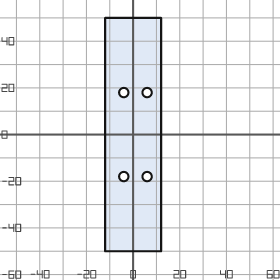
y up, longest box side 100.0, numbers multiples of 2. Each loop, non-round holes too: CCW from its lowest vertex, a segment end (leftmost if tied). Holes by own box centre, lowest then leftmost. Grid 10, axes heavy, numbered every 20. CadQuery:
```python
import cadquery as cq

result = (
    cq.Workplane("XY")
    .moveTo(-12.0, -50.0)
    .lineTo(12.0, -50.0)
    .lineTo(12.0, 50.0)
    .lineTo(-12.0, 50.0)
    .close()
    .moveTo(-4.0, -18.0)
    .circle(2.0)
    .moveTo(6.0, -18.0)
    .circle(2.0)
    .moveTo(-4.0, 18.0)
    .circle(2.0)
    .moveTo(6.0, 18.0)
    .circle(2.0)
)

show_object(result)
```